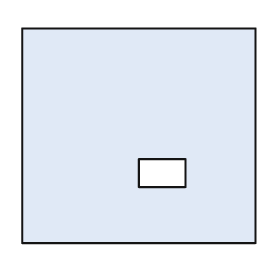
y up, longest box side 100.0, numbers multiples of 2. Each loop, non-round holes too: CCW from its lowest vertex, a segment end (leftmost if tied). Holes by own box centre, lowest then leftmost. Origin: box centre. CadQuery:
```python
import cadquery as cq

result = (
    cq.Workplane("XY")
    .moveTo(-50.0, -46.0)
    .lineTo(50.0, -46.0)
    .lineTo(50.0, 46.0)
    .lineTo(-50.0, 46.0)
    .close()
    .moveTo(0.0, -22.0)
    .lineTo(20.0, -22.0)
    .lineTo(20.0, -10.0)
    .lineTo(0.0, -10.0)
    .close()
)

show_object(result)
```